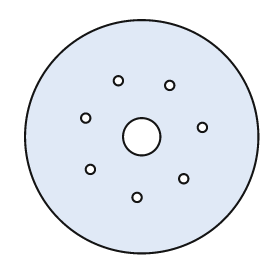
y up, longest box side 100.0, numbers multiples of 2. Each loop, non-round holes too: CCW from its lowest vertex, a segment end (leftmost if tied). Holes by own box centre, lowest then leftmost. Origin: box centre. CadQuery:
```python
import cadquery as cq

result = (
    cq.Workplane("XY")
    .moveTo(0.0, 0.0)
    .circle(50.0)
    .moveTo(-2.0, -26.0)
    .circle(2.0)
    .moveTo(18.0, -18.0)
    .circle(2.0)
    .moveTo(-22.0, -14.0)
    .circle(2.0)
    .moveTo(0.0, 0.0)
    .circle(8.0)
    .moveTo(26.0, 4.0)
    .circle(2.0)
    .moveTo(-24.0, 8.0)
    .circle(2.0)
    .moveTo(12.0, 22.0)
    .circle(2.0)
    .moveTo(-10.0, 24.0)
    .circle(2.0)
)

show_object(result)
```